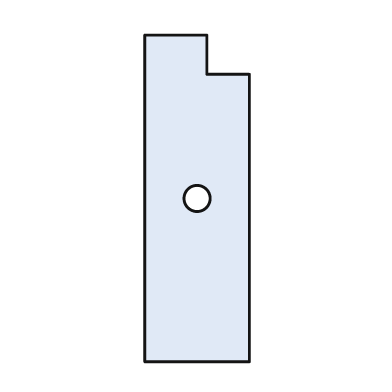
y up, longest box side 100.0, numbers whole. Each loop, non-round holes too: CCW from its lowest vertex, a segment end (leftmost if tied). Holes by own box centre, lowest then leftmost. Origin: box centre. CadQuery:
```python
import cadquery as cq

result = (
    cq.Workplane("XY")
    .moveTo(-16.0, -50.0)
    .lineTo(16.0, -50.0)
    .lineTo(16.0, 38.0)
    .lineTo(3.0, 38.0)
    .lineTo(3.0, 50.0)
    .lineTo(-16.0, 50.0)
    .close()
    .moveTo(0.0, 0.0)
    .circle(4.0)
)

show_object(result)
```